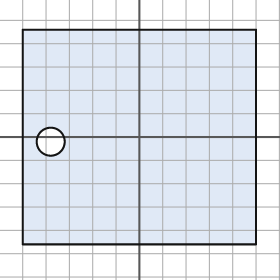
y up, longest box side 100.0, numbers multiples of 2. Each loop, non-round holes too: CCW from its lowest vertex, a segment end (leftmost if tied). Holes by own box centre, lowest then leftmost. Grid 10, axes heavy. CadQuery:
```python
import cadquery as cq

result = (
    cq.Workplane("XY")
    .moveTo(-50.0, -46.0)
    .lineTo(50.0, -46.0)
    .lineTo(50.0, 46.0)
    .lineTo(-50.0, 46.0)
    .close()
    .moveTo(-38.0, -2.0)
    .circle(6.0)
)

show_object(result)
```